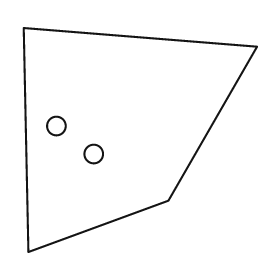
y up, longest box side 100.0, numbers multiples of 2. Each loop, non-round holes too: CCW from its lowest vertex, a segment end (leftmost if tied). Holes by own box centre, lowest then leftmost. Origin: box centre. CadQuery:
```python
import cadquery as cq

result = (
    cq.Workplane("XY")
    .moveTo(-48.0, -48.0)
    .lineTo(12.0, -26.0)
    .lineTo(50.0, 40.0)
    .lineTo(-50.0, 48.0)
    .close()
    .moveTo(-20.0, -6.0)
    .circle(4.0)
    .moveTo(-36.0, 6.0)
    .circle(4.0)
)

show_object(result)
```